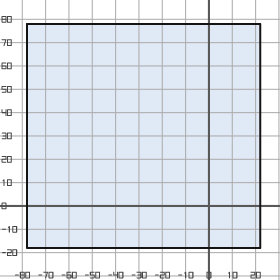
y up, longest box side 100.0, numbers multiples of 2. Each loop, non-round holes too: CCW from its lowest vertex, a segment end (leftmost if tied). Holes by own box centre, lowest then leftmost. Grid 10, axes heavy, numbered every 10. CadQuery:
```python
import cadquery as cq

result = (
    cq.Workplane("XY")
    .moveTo(-78.0, -18.0)
    .lineTo(22.0, -18.0)
    .lineTo(22.0, 78.0)
    .lineTo(-78.0, 78.0)
    .close()
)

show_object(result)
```